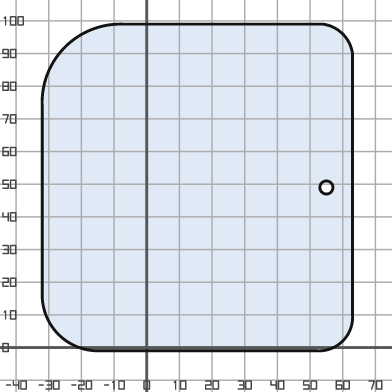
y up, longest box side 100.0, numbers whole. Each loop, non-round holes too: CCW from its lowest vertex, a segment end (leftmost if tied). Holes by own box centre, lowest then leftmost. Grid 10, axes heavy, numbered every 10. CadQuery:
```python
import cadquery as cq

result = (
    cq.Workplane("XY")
    .moveTo(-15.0, -1.0)
    .lineTo(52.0, -1.0)
    .threePointArc((60.0, 2.0), (63.0, 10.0))
    .lineTo(63.0, 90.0)
    .threePointArc((60.0, 96.0), (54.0, 99.0))
    .lineTo(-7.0, 99.0)
    .threePointArc((-25.0, 92.0), (-32.0, 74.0))
    .lineTo(-32.0, 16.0)
    .threePointArc((-27.0, 4.0), (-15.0, -1.0))
    .close()
    .moveTo(55.0, 49.0)
    .circle(2.0)
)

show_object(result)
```